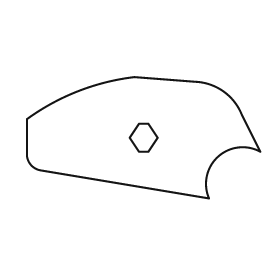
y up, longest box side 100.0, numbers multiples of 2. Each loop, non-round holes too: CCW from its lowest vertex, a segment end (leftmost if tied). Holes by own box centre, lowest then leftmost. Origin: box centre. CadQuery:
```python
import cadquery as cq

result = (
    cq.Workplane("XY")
    .moveTo(28.0, -26.0)
    .threePointArc((32.0, -8.0), (50.0, -6.0))
    .lineTo(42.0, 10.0)
    .threePointArc((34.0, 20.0), (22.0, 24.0))
    .lineTo(-4.0, 26.0)
    .threePointArc((-28.0, 20.0), (-50.0, 8.0))
    .lineTo(-50.0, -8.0)
    .threePointArc((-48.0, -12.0), (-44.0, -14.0))
    .close()
    .moveTo(-2.0, -6.0)
    .lineTo(2.0, -6.0)
    .lineTo(6.0, 0.0)
    .lineTo(2.0, 6.0)
    .lineTo(-2.0, 6.0)
    .lineTo(-6.0, 0.0)
    .close()
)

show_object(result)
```